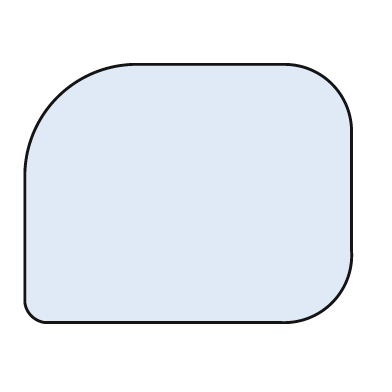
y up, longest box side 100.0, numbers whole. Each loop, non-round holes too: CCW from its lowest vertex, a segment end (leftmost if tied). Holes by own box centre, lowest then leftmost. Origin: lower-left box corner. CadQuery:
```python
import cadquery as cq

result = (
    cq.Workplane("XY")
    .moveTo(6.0, 0.0)
    .lineTo(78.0, 0.0)
    .threePointArc((94.0, 6.0), (100.0, 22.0))
    .lineTo(100.0, 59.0)
    .threePointArc((94.0, 73.0), (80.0, 79.0))
    .lineTo(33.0, 79.0)
    .threePointArc((10.0, 69.0), (0.0, 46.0))
    .lineTo(0.0, 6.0)
    .threePointArc((2.0, 2.0), (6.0, 0.0))
    .close()
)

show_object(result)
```